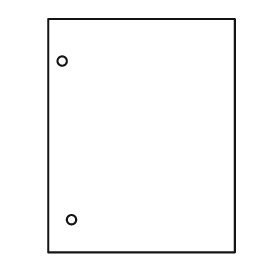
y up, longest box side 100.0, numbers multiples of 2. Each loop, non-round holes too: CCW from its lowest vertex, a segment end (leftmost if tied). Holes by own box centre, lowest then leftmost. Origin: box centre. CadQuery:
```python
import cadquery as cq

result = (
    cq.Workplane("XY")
    .moveTo(-40.0, -50.0)
    .lineTo(40.0, -50.0)
    .lineTo(40.0, 50.0)
    .lineTo(-40.0, 50.0)
    .close()
    .moveTo(-30.0, -36.0)
    .circle(2.0)
    .moveTo(-34.0, 32.0)
    .circle(2.0)
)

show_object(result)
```